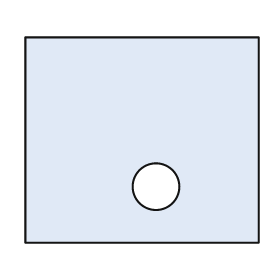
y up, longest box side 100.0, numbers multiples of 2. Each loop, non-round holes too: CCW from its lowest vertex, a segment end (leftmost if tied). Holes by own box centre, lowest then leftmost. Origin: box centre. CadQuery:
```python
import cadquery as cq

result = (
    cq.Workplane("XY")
    .moveTo(-50.0, -44.0)
    .lineTo(50.0, -44.0)
    .lineTo(50.0, 44.0)
    .lineTo(-50.0, 44.0)
    .close()
    .moveTo(6.0, -20.0)
    .circle(10.0)
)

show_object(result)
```